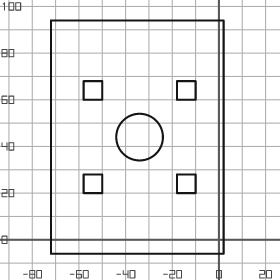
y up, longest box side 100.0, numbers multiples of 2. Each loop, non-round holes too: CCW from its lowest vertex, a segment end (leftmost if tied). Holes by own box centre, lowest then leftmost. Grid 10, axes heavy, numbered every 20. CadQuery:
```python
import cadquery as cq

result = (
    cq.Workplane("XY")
    .moveTo(-72.0, -6.0)
    .lineTo(2.0, -6.0)
    .lineTo(2.0, 94.0)
    .lineTo(-72.0, 94.0)
    .close()
    .moveTo(-58.0, 20.0)
    .lineTo(-50.0, 20.0)
    .lineTo(-50.0, 28.0)
    .lineTo(-58.0, 28.0)
    .close()
    .moveTo(-18.0, 20.0)
    .lineTo(-10.0, 20.0)
    .lineTo(-10.0, 28.0)
    .lineTo(-18.0, 28.0)
    .close()
    .moveTo(-34.0, 44.0)
    .circle(10.0)
    .moveTo(-58.0, 60.0)
    .lineTo(-50.0, 60.0)
    .lineTo(-50.0, 68.0)
    .lineTo(-58.0, 68.0)
    .close()
    .moveTo(-18.0, 60.0)
    .lineTo(-10.0, 60.0)
    .lineTo(-10.0, 68.0)
    .lineTo(-18.0, 68.0)
    .close()
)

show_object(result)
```